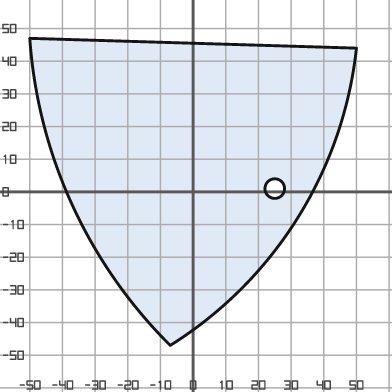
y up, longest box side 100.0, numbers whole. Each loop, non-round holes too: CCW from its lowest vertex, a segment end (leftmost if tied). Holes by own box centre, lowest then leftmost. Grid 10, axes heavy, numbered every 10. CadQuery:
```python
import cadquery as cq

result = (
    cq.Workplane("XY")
    .moveTo(-7.0, -47.0)
    .threePointArc((32.0, -8.0), (50.0, 44.0))
    .lineTo(-50.0, 47.0)
    .threePointArc((-37.0, -4.0), (-7.0, -47.0))
    .close()
    .moveTo(25.0, 1.0)
    .circle(3.0)
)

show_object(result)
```